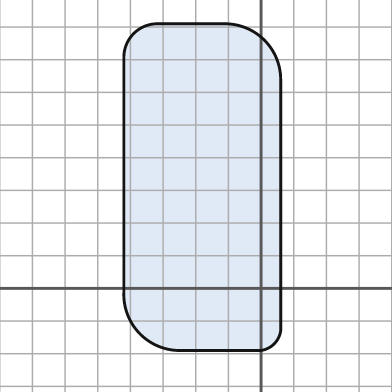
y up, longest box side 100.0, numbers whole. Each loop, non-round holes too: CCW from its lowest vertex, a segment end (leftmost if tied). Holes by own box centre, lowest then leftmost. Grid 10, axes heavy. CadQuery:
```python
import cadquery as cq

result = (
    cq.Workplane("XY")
    .moveTo(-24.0, -19.0)
    .lineTo(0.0, -19.0)
    .threePointArc((4.0, -17.0), (6.0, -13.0))
    .lineTo(6.0, 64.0)
    .threePointArc((1.0, 76.0), (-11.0, 81.0))
    .lineTo(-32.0, 81.0)
    .threePointArc((-39.0, 78.0), (-42.0, 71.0))
    .lineTo(-42.0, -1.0)
    .threePointArc((-37.0, -14.0), (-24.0, -19.0))
    .close()
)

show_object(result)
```